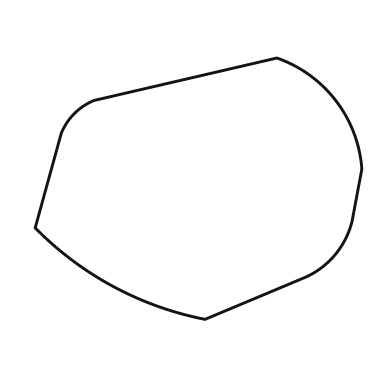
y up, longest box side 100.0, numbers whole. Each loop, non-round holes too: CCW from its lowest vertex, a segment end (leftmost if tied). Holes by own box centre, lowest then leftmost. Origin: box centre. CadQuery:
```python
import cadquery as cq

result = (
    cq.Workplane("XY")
    .moveTo(2.0, -40.0)
    .lineTo(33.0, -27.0)
    .threePointArc((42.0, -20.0), (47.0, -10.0))
    .lineTo(50.0, 6.0)
    .threePointArc((42.0, 27.0), (24.0, 40.0))
    .lineTo(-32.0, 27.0)
    .threePointArc((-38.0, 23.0), (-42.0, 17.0))
    .lineTo(-50.0, -12.0)
    .threePointArc((-26.0, -30.0), (2.0, -40.0))
    .close()
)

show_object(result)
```